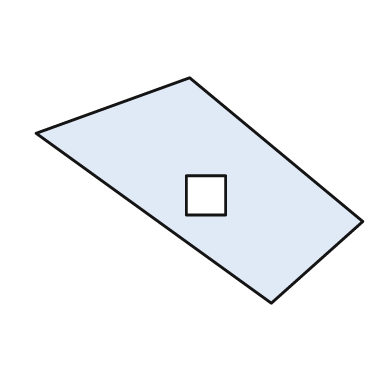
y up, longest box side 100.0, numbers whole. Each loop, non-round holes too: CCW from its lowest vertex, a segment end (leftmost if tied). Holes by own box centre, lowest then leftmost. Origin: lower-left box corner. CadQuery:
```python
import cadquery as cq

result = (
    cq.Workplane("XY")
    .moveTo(72.0, 0.0)
    .lineTo(100.0, 25.0)
    .lineTo(47.0, 69.0)
    .lineTo(0.0, 52.0)
    .close()
    .moveTo(46.0, 27.0)
    .lineTo(58.0, 27.0)
    .lineTo(58.0, 39.0)
    .lineTo(46.0, 39.0)
    .close()
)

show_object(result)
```